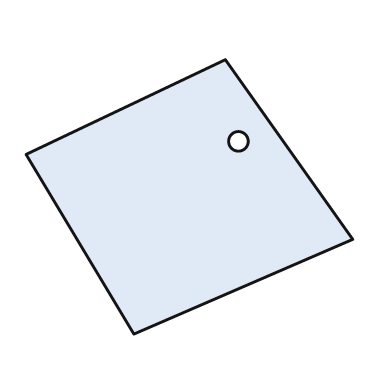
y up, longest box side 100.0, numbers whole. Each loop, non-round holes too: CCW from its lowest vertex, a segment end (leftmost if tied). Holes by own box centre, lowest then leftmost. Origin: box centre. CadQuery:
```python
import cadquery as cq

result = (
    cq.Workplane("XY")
    .moveTo(-17.0, -42.0)
    .lineTo(50.0, -13.0)
    .lineTo(11.0, 42.0)
    .lineTo(-50.0, 13.0)
    .close()
    .moveTo(15.0, 17.0)
    .circle(3.0)
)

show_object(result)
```